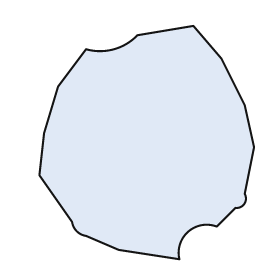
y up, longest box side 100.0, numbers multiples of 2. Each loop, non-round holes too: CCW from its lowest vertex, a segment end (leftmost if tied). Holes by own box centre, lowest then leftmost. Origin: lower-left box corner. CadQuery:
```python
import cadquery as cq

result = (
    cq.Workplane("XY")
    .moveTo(60.0, 0.0)
    .threePointArc((64.0, 12.0), (76.0, 14.0))
    .lineTo(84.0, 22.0)
    .threePointArc((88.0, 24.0), (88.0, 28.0))
    .lineTo(92.0, 48.0)
    .lineTo(88.0, 66.0)
    .lineTo(78.0, 86.0)
    .lineTo(66.0, 100.0)
    .lineTo(42.0, 96.0)
    .threePointArc((32.0, 90.0), (20.0, 90.0))
    .lineTo(8.0, 74.0)
    .lineTo(2.0, 54.0)
    .lineTo(0.0, 36.0)
    .lineTo(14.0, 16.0)
    .threePointArc((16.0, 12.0), (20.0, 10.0))
    .lineTo(34.0, 4.0)
    .close()
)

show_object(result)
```